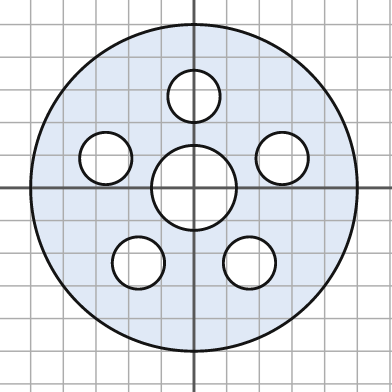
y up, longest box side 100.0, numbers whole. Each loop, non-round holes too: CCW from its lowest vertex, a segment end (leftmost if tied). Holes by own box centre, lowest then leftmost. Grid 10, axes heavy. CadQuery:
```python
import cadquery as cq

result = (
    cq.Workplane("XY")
    .moveTo(0.0, 0.0)
    .circle(50.0)
    .moveTo(-17.0, -23.0)
    .circle(8.0)
    .moveTo(17.0, -23.0)
    .circle(8.0)
    .moveTo(0.0, 0.0)
    .circle(13.0)
    .moveTo(-27.0, 9.0)
    .circle(8.0)
    .moveTo(27.0, 9.0)
    .circle(8.0)
    .moveTo(0.0, 28.0)
    .circle(8.0)
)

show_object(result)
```